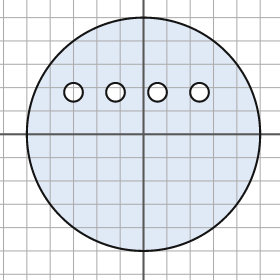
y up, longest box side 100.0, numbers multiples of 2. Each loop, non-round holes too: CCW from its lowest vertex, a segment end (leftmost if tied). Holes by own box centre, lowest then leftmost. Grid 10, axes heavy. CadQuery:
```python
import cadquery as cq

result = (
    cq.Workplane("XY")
    .moveTo(0.0, 0.0)
    .circle(50.0)
    .moveTo(-30.0, 18.0)
    .circle(4.0)
    .moveTo(-12.0, 18.0)
    .circle(4.0)
    .moveTo(6.0, 18.0)
    .circle(4.0)
    .moveTo(24.0, 18.0)
    .circle(4.0)
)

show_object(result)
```